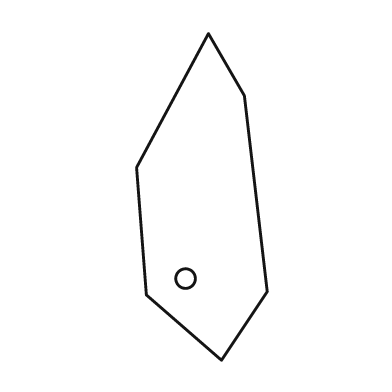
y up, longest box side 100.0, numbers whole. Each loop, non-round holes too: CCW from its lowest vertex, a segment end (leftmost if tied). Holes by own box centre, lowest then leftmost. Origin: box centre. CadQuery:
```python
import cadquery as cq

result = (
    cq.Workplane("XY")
    .moveTo(6.0, -50.0)
    .lineTo(20.0, -29.0)
    .lineTo(13.0, 31.0)
    .lineTo(2.0, 50.0)
    .lineTo(-20.0, 9.0)
    .lineTo(-17.0, -30.0)
    .close()
    .moveTo(-5.0, -25.0)
    .circle(3.0)
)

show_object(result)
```